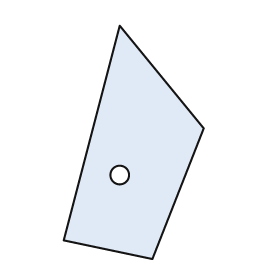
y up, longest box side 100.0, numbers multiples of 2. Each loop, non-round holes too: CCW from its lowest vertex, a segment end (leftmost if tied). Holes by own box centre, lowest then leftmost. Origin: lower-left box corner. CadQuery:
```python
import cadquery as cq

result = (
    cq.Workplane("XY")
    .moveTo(38.0, 0.0)
    .lineTo(60.0, 56.0)
    .lineTo(24.0, 100.0)
    .lineTo(0.0, 8.0)
    .close()
    .moveTo(24.0, 36.0)
    .circle(4.0)
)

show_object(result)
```